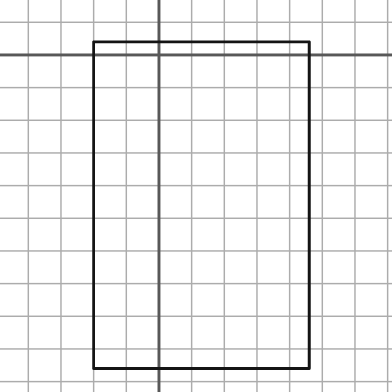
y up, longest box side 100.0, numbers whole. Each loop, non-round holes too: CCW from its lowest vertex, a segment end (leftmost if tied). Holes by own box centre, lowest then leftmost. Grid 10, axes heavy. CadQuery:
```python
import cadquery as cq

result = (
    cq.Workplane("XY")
    .moveTo(-20.0, -96.0)
    .lineTo(46.0, -96.0)
    .lineTo(46.0, 4.0)
    .lineTo(-20.0, 4.0)
    .close()
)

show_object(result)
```